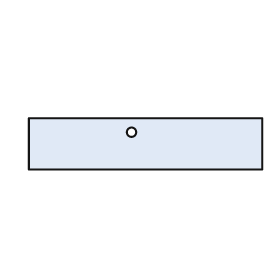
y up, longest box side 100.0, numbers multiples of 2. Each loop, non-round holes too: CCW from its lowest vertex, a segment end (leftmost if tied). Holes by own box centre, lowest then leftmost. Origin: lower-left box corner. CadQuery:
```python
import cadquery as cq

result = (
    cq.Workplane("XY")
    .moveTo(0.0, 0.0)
    .lineTo(100.0, 0.0)
    .lineTo(100.0, 22.0)
    .lineTo(0.0, 22.0)
    .close()
    .moveTo(44.0, 16.0)
    .circle(2.0)
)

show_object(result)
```